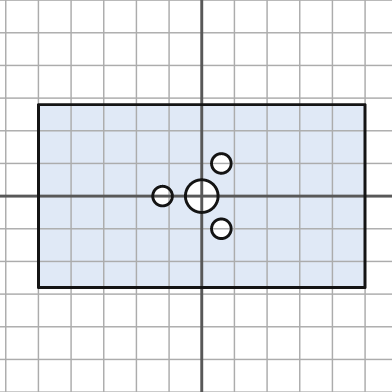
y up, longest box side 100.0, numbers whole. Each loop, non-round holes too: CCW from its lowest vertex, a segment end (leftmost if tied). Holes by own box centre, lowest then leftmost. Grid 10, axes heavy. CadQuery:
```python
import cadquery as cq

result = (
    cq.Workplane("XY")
    .moveTo(-50.0, -28.0)
    .lineTo(50.0, -28.0)
    .lineTo(50.0, 28.0)
    .lineTo(-50.0, 28.0)
    .close()
    .moveTo(6.0, -10.0)
    .circle(3.0)
    .moveTo(-12.0, 0.0)
    .circle(3.0)
    .moveTo(0.0, 0.0)
    .circle(5.0)
    .moveTo(6.0, 10.0)
    .circle(3.0)
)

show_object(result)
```